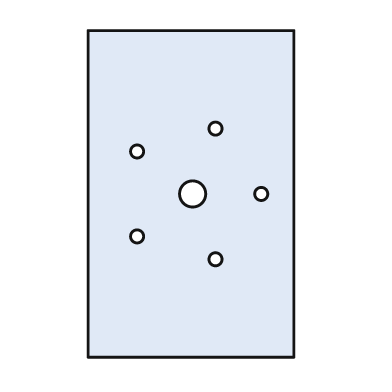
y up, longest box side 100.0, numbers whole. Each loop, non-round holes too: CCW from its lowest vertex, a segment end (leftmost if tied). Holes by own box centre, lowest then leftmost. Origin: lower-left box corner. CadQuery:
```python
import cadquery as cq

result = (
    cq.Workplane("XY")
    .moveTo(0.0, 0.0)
    .lineTo(63.0, 0.0)
    .lineTo(63.0, 100.0)
    .lineTo(0.0, 100.0)
    .close()
    .moveTo(39.0, 30.0)
    .circle(2.0)
    .moveTo(15.0, 37.0)
    .circle(2.0)
    .moveTo(32.0, 50.0)
    .circle(4.0)
    .moveTo(53.0, 50.0)
    .circle(2.0)
    .moveTo(15.0, 63.0)
    .circle(2.0)
    .moveTo(39.0, 70.0)
    .circle(2.0)
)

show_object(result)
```